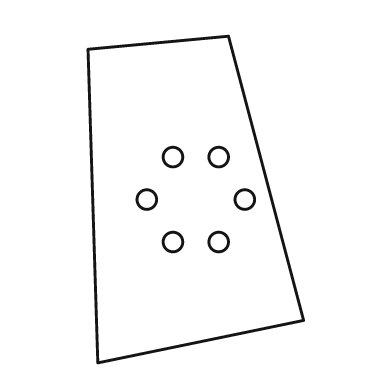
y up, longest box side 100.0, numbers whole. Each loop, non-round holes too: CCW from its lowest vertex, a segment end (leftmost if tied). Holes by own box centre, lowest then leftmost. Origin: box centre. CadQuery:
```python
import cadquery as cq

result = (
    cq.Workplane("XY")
    .moveTo(-30.0, -50.0)
    .lineTo(33.0, -37.0)
    .lineTo(10.0, 50.0)
    .lineTo(-33.0, 46.0)
    .close()
    .moveTo(-7.0, -13.0)
    .circle(3.0)
    .moveTo(7.0, -13.0)
    .circle(3.0)
    .moveTo(-15.0, 0.0)
    .circle(3.0)
    .moveTo(15.0, 0.0)
    .circle(3.0)
    .moveTo(-7.0, 13.0)
    .circle(3.0)
    .moveTo(7.0, 13.0)
    .circle(3.0)
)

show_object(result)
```